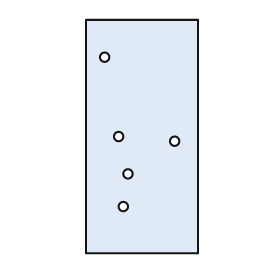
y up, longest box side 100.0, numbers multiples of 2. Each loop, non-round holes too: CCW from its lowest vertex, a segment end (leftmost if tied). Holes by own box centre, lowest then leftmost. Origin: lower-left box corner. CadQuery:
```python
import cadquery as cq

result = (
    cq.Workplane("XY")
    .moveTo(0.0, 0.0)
    .lineTo(48.0, 0.0)
    .lineTo(48.0, 100.0)
    .lineTo(0.0, 100.0)
    .close()
    .moveTo(16.0, 20.0)
    .circle(2.0)
    .moveTo(18.0, 34.0)
    .circle(2.0)
    .moveTo(38.0, 48.0)
    .circle(2.0)
    .moveTo(14.0, 50.0)
    .circle(2.0)
    .moveTo(8.0, 84.0)
    .circle(2.0)
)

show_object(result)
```